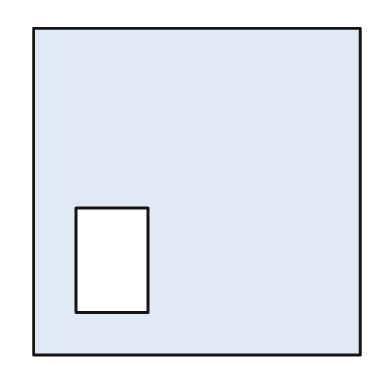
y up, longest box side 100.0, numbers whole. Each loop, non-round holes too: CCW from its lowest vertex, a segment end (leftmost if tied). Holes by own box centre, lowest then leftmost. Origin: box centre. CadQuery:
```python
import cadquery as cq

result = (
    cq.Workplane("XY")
    .moveTo(-50.0, -50.0)
    .lineTo(50.0, -50.0)
    .lineTo(50.0, 50.0)
    .lineTo(-50.0, 50.0)
    .close()
    .moveTo(-37.0, -37.0)
    .lineTo(-15.0, -37.0)
    .lineTo(-15.0, -5.0)
    .lineTo(-37.0, -5.0)
    .close()
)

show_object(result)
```